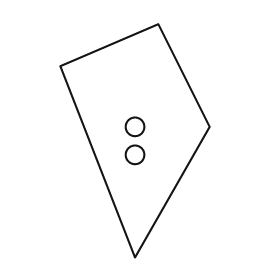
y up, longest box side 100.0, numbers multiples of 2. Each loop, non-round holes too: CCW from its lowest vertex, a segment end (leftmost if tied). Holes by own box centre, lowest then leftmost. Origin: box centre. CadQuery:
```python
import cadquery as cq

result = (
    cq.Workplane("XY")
    .moveTo(0.0, -50.0)
    .lineTo(32.0, 6.0)
    .lineTo(10.0, 50.0)
    .lineTo(-32.0, 32.0)
    .close()
    .moveTo(0.0, -6.0)
    .circle(4.0)
    .moveTo(0.0, 6.0)
    .circle(4.0)
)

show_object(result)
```